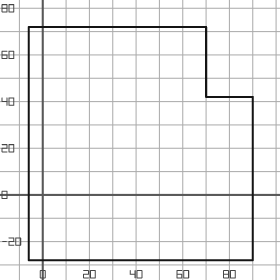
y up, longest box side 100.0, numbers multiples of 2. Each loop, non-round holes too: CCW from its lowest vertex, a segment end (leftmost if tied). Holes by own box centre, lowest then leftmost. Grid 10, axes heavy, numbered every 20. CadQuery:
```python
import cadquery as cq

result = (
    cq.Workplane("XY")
    .moveTo(-6.0, -28.0)
    .lineTo(90.0, -28.0)
    .lineTo(90.0, 42.0)
    .lineTo(70.0, 42.0)
    .lineTo(70.0, 72.0)
    .lineTo(-6.0, 72.0)
    .close()
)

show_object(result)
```